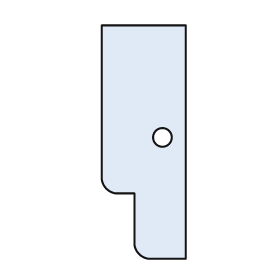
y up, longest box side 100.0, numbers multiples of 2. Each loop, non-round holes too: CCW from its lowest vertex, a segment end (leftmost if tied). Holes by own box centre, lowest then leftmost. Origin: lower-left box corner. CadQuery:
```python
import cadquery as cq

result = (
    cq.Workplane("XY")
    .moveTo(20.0, 0.0)
    .lineTo(36.0, 0.0)
    .lineTo(36.0, 100.0)
    .lineTo(0.0, 100.0)
    .lineTo(0.0, 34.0)
    .threePointArc((2.0, 30.0), (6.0, 28.0))
    .lineTo(14.0, 28.0)
    .lineTo(14.0, 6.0)
    .threePointArc((16.0, 2.0), (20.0, 0.0))
    .close()
    .moveTo(26.0, 52.0)
    .circle(4.0)
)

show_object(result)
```